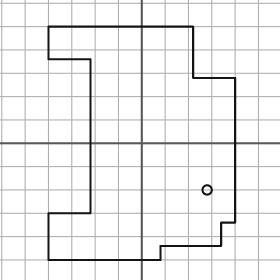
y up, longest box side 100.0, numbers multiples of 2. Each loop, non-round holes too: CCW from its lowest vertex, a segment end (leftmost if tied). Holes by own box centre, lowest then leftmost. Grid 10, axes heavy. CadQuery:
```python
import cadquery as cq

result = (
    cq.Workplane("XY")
    .moveTo(-40.0, -50.0)
    .lineTo(8.0, -50.0)
    .lineTo(8.0, -44.0)
    .lineTo(34.0, -44.0)
    .lineTo(34.0, -34.0)
    .lineTo(40.0, -34.0)
    .lineTo(40.0, 28.0)
    .lineTo(22.0, 28.0)
    .lineTo(22.0, 50.0)
    .lineTo(-40.0, 50.0)
    .lineTo(-40.0, 36.0)
    .lineTo(-22.0, 36.0)
    .lineTo(-22.0, -30.0)
    .lineTo(-40.0, -30.0)
    .close()
    .moveTo(28.0, -20.0)
    .circle(2.0)
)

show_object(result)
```